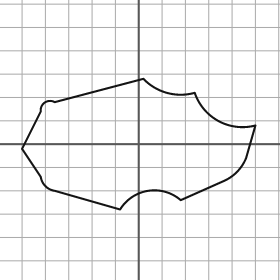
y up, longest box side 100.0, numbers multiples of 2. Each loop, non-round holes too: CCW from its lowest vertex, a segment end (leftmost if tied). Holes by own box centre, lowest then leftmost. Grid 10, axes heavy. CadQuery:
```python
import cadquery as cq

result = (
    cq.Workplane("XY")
    .moveTo(-8.0, -28.0)
    .threePointArc((4.0, -20.0), (18.0, -24.0))
    .lineTo(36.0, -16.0)
    .threePointArc((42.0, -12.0), (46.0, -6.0))
    .lineTo(50.0, 8.0)
    .threePointArc((34.0, 10.0), (24.0, 22.0))
    .threePointArc((12.0, 22.0), (2.0, 28.0))
    .lineTo(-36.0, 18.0)
    .threePointArc((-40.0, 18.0), (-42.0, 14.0))
    .lineTo(-50.0, -2.0)
    .lineTo(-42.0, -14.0)
    .threePointArc((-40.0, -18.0), (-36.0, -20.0))
    .close()
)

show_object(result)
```